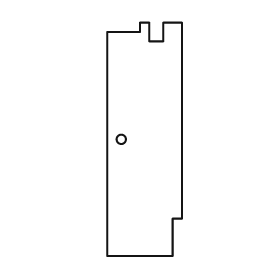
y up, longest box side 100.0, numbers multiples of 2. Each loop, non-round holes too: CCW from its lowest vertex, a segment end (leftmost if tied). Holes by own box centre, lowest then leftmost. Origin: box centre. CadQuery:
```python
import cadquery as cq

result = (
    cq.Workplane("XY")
    .moveTo(-16.0, -50.0)
    .lineTo(12.0, -50.0)
    .lineTo(12.0, -34.0)
    .lineTo(16.0, -34.0)
    .lineTo(16.0, 50.0)
    .lineTo(8.0, 50.0)
    .lineTo(8.0, 42.0)
    .lineTo(2.0, 42.0)
    .lineTo(2.0, 50.0)
    .lineTo(-2.0, 50.0)
    .lineTo(-2.0, 46.0)
    .lineTo(-16.0, 46.0)
    .close()
    .moveTo(-10.0, 0.0)
    .circle(2.0)
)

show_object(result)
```